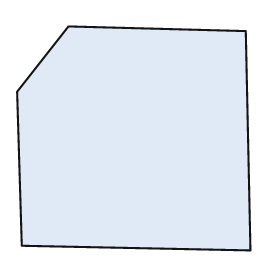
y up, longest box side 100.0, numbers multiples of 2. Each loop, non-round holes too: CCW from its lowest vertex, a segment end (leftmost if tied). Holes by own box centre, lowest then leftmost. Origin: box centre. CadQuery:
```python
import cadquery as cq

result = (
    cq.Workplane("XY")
    .moveTo(50.0, -48.0)
    .lineTo(48.0, 46.0)
    .lineTo(-28.0, 48.0)
    .lineTo(-50.0, 20.0)
    .lineTo(-48.0, -46.0)
    .close()
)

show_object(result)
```